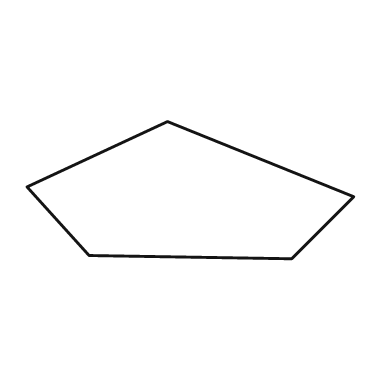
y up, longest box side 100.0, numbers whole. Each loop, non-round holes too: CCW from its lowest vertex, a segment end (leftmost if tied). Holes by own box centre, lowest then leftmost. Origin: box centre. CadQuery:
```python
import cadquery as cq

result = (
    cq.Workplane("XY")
    .moveTo(31.0, -21.0)
    .lineTo(50.0, -2.0)
    .lineTo(-7.0, 21.0)
    .lineTo(-50.0, 1.0)
    .lineTo(-31.0, -20.0)
    .close()
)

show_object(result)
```